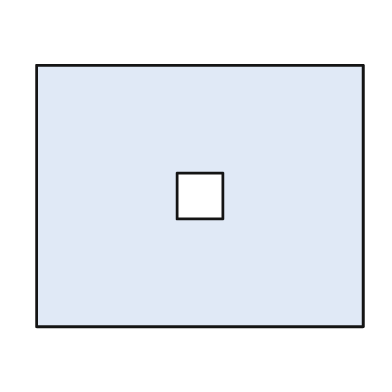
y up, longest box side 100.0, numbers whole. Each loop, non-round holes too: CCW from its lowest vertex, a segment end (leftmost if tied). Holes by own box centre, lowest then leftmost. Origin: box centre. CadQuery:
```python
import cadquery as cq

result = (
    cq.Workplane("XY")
    .moveTo(-50.0, -40.0)
    .lineTo(50.0, -40.0)
    .lineTo(50.0, 40.0)
    .lineTo(-50.0, 40.0)
    .close()
    .moveTo(-7.0, -7.0)
    .lineTo(7.0, -7.0)
    .lineTo(7.0, 7.0)
    .lineTo(-7.0, 7.0)
    .close()
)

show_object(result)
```